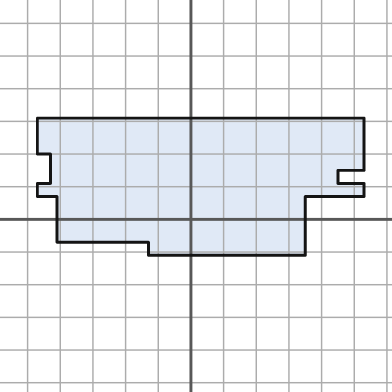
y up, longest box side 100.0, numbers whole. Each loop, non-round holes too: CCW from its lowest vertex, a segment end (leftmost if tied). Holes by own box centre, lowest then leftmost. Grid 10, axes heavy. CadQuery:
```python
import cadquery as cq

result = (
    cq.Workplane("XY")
    .moveTo(-13.0, -11.0)
    .lineTo(35.0, -11.0)
    .lineTo(35.0, 7.0)
    .lineTo(53.0, 7.0)
    .lineTo(53.0, 11.0)
    .lineTo(45.0, 11.0)
    .lineTo(45.0, 15.0)
    .lineTo(53.0, 15.0)
    .lineTo(53.0, 31.0)
    .lineTo(-47.0, 31.0)
    .lineTo(-47.0, 20.0)
    .lineTo(-43.0, 20.0)
    .lineTo(-43.0, 11.0)
    .lineTo(-47.0, 11.0)
    .lineTo(-47.0, 7.0)
    .lineTo(-41.0, 7.0)
    .lineTo(-41.0, -7.0)
    .lineTo(-13.0, -7.0)
    .close()
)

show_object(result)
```